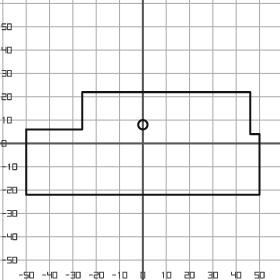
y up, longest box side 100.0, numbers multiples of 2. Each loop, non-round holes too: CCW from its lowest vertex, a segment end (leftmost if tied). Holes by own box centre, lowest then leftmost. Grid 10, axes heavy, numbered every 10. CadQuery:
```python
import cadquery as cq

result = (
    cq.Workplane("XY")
    .moveTo(-50.0, -22.0)
    .lineTo(50.0, -22.0)
    .lineTo(50.0, 4.0)
    .lineTo(46.0, 4.0)
    .lineTo(46.0, 22.0)
    .lineTo(-26.0, 22.0)
    .lineTo(-26.0, 6.0)
    .lineTo(-50.0, 6.0)
    .close()
    .moveTo(0.0, 8.0)
    .circle(2.0)
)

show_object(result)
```